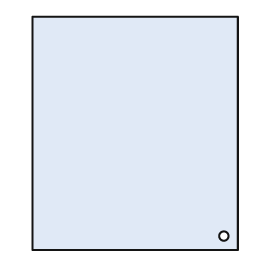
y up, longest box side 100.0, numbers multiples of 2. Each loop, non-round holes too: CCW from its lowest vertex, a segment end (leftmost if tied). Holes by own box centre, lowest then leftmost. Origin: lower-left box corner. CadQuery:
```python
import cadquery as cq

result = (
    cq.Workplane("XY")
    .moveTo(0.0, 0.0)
    .lineTo(88.0, 0.0)
    .lineTo(88.0, 100.0)
    .lineTo(0.0, 100.0)
    .close()
    .moveTo(82.0, 6.0)
    .circle(2.0)
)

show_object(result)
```